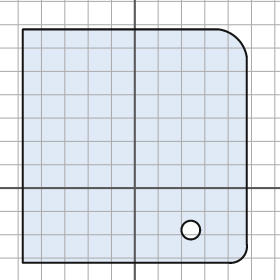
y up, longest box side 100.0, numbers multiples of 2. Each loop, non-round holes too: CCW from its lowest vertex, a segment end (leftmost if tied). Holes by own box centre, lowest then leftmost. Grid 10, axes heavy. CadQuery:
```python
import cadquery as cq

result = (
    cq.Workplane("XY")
    .moveTo(-48.0, -32.0)
    .lineTo(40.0, -32.0)
    .threePointArc((46.0, -30.0), (48.0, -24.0))
    .lineTo(48.0, 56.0)
    .threePointArc((44.0, 64.0), (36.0, 68.0))
    .lineTo(-48.0, 68.0)
    .close()
    .moveTo(24.0, -18.0)
    .circle(4.0)
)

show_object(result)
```